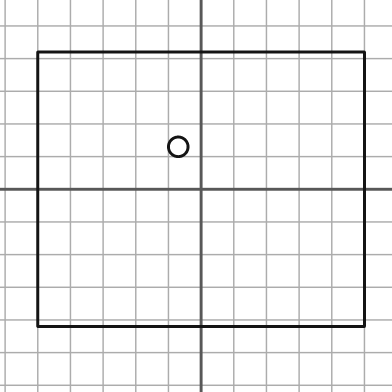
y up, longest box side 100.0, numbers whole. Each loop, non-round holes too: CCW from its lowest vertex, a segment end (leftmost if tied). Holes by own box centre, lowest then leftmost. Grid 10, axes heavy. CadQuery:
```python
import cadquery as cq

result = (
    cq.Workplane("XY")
    .moveTo(-50.0, -42.0)
    .lineTo(50.0, -42.0)
    .lineTo(50.0, 42.0)
    .lineTo(-50.0, 42.0)
    .close()
    .moveTo(-7.0, 13.0)
    .circle(3.0)
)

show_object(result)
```